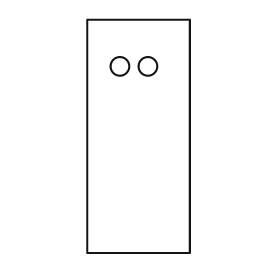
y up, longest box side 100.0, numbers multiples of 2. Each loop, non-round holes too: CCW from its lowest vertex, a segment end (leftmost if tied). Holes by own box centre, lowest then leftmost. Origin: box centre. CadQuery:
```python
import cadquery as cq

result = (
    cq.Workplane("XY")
    .moveTo(-22.0, -50.0)
    .lineTo(22.0, -50.0)
    .lineTo(22.0, 50.0)
    .lineTo(-22.0, 50.0)
    .close()
    .moveTo(-8.0, 30.0)
    .circle(4.0)
    .moveTo(4.0, 30.0)
    .circle(4.0)
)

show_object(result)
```